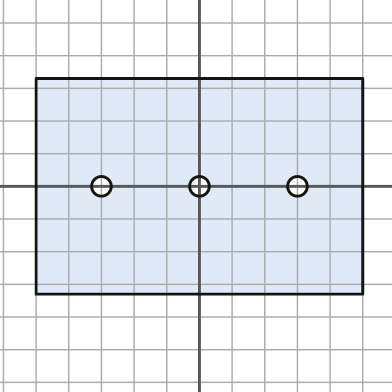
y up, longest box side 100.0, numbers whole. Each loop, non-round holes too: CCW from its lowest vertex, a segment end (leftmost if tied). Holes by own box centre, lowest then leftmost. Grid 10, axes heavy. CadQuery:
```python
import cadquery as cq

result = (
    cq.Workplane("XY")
    .moveTo(-50.0, -33.0)
    .lineTo(50.0, -33.0)
    .lineTo(50.0, 33.0)
    .lineTo(-50.0, 33.0)
    .close()
    .moveTo(-30.0, 0.0)
    .circle(3.0)
    .moveTo(0.0, 0.0)
    .circle(3.0)
    .moveTo(30.0, 0.0)
    .circle(3.0)
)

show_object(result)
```